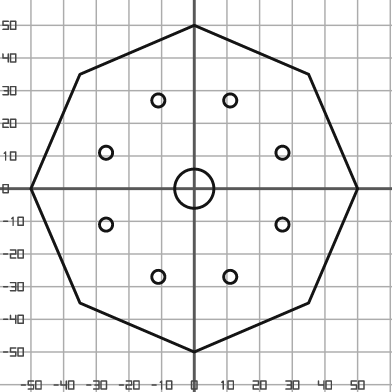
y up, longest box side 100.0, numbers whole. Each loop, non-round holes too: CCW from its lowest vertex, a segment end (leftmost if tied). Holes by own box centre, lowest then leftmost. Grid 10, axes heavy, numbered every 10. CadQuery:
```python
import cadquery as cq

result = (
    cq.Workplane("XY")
    .moveTo(0.0, -50.0)
    .lineTo(35.0, -35.0)
    .lineTo(50.0, 0.0)
    .lineTo(35.0, 35.0)
    .lineTo(0.0, 50.0)
    .lineTo(-35.0, 35.0)
    .lineTo(-50.0, 0.0)
    .lineTo(-35.0, -35.0)
    .close()
    .moveTo(-11.0, -27.0)
    .circle(2.0)
    .moveTo(11.0, -27.0)
    .circle(2.0)
    .moveTo(-27.0, -11.0)
    .circle(2.0)
    .moveTo(27.0, -11.0)
    .circle(2.0)
    .moveTo(0.0, 0.0)
    .circle(6.0)
    .moveTo(-27.0, 11.0)
    .circle(2.0)
    .moveTo(27.0, 11.0)
    .circle(2.0)
    .moveTo(-11.0, 27.0)
    .circle(2.0)
    .moveTo(11.0, 27.0)
    .circle(2.0)
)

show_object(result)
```